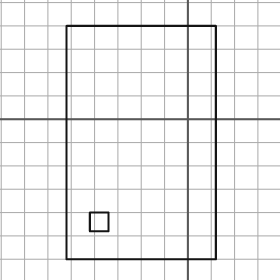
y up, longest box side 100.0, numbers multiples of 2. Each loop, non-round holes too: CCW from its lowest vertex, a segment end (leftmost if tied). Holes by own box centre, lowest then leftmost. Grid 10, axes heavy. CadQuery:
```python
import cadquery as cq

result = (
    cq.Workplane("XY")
    .moveTo(-52.0, -60.0)
    .lineTo(12.0, -60.0)
    .lineTo(12.0, 40.0)
    .lineTo(-52.0, 40.0)
    .close()
    .moveTo(-42.0, -48.0)
    .lineTo(-34.0, -48.0)
    .lineTo(-34.0, -40.0)
    .lineTo(-42.0, -40.0)
    .close()
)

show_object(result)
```